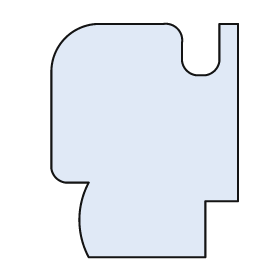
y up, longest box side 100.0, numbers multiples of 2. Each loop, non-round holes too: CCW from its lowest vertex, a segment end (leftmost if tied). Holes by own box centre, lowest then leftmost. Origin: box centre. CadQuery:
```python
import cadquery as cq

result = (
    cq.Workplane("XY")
    .moveTo(-24.0, -50.0)
    .lineTo(26.0, -50.0)
    .lineTo(26.0, -26.0)
    .lineTo(40.0, -26.0)
    .lineTo(40.0, 50.0)
    .lineTo(32.0, 50.0)
    .lineTo(32.0, 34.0)
    .threePointArc((30.0, 30.0), (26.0, 28.0))
    .lineTo(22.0, 28.0)
    .threePointArc((18.0, 30.0), (16.0, 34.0))
    .lineTo(16.0, 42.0)
    .threePointArc((14.0, 48.0), (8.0, 50.0))
    .lineTo(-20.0, 50.0)
    .threePointArc((-34.0, 44.0), (-40.0, 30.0))
    .lineTo(-40.0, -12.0)
    .threePointArc((-38.0, -16.0), (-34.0, -18.0))
    .lineTo(-24.0, -18.0)
    .threePointArc((-28.0, -34.0), (-24.0, -50.0))
    .close()
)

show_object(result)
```